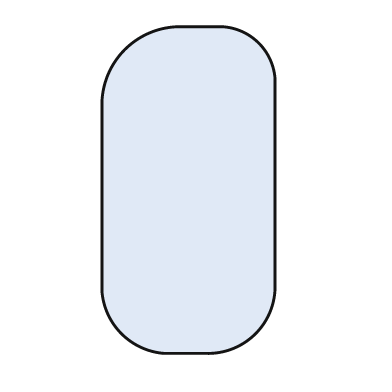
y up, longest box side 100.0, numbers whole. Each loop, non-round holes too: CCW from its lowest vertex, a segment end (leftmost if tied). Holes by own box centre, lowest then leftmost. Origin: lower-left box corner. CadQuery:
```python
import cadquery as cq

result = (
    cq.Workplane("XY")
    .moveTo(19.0, 0.0)
    .lineTo(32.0, 0.0)
    .threePointArc((47.0, 6.0), (53.0, 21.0))
    .lineTo(53.0, 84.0)
    .threePointArc((48.0, 95.0), (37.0, 100.0))
    .lineTo(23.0, 100.0)
    .threePointArc((7.0, 93.0), (0.0, 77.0))
    .lineTo(0.0, 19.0)
    .threePointArc((6.0, 6.0), (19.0, 0.0))
    .close()
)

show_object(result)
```